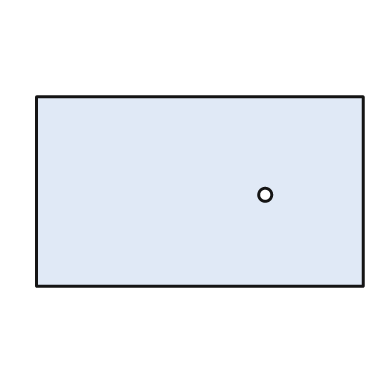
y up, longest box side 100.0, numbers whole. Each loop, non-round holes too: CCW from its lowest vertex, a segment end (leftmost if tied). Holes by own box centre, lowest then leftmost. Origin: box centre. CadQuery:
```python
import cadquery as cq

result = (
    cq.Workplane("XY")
    .moveTo(-50.0, -29.0)
    .lineTo(50.0, -29.0)
    .lineTo(50.0, 29.0)
    .lineTo(-50.0, 29.0)
    .close()
    .moveTo(20.0, -1.0)
    .circle(2.0)
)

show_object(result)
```